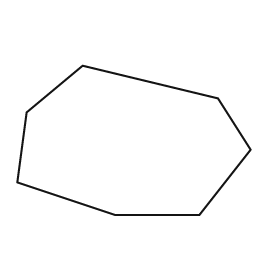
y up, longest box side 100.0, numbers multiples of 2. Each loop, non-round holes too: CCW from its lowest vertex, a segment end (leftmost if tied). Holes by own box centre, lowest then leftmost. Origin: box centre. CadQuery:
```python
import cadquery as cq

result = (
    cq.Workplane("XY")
    .moveTo(-8.0, -32.0)
    .lineTo(28.0, -32.0)
    .lineTo(50.0, -4.0)
    .lineTo(36.0, 18.0)
    .lineTo(-22.0, 32.0)
    .lineTo(-46.0, 12.0)
    .lineTo(-50.0, -18.0)
    .close()
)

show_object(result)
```